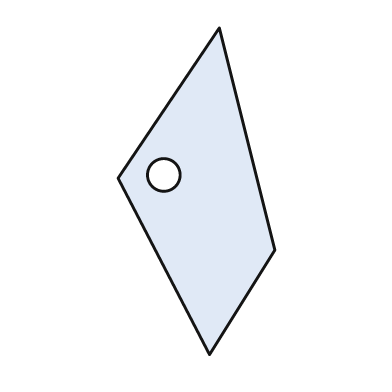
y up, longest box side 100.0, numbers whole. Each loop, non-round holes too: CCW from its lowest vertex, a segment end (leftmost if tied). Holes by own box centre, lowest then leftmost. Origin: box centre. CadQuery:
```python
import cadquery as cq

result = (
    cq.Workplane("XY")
    .moveTo(4.0, -50.0)
    .lineTo(24.0, -18.0)
    .lineTo(7.0, 50.0)
    .lineTo(-24.0, 4.0)
    .close()
    .moveTo(-10.0, 5.0)
    .circle(5.0)
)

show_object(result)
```